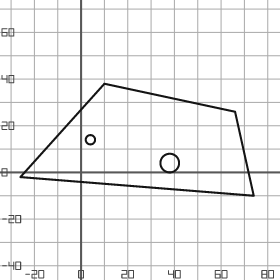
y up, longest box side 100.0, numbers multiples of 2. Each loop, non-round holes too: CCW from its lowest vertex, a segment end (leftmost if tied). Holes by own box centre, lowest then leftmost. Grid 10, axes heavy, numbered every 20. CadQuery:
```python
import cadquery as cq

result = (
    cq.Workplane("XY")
    .moveTo(74.0, -10.0)
    .lineTo(66.0, 26.0)
    .lineTo(10.0, 38.0)
    .lineTo(-26.0, -2.0)
    .close()
    .moveTo(38.0, 4.0)
    .circle(4.0)
    .moveTo(4.0, 14.0)
    .circle(2.0)
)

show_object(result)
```